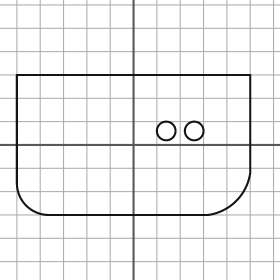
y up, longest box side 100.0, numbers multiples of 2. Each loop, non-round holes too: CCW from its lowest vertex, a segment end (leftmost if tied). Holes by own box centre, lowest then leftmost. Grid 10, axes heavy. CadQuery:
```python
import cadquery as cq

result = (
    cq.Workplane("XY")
    .moveTo(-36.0, -30.0)
    .lineTo(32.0, -30.0)
    .threePointArc((44.0, -24.0), (50.0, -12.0))
    .lineTo(50.0, 30.0)
    .lineTo(-50.0, 30.0)
    .lineTo(-50.0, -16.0)
    .threePointArc((-46.0, -26.0), (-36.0, -30.0))
    .close()
    .moveTo(14.0, 6.0)
    .circle(4.0)
    .moveTo(26.0, 6.0)
    .circle(4.0)
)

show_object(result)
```